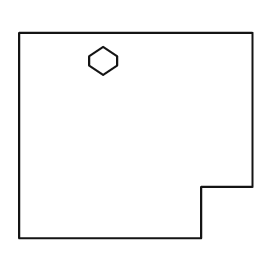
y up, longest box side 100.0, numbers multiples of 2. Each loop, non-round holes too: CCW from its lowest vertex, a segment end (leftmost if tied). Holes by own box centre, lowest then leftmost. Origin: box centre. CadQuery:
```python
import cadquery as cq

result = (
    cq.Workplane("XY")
    .moveTo(-50.0, -44.0)
    .lineTo(28.0, -44.0)
    .lineTo(28.0, -22.0)
    .lineTo(50.0, -22.0)
    .lineTo(50.0, 44.0)
    .lineTo(-50.0, 44.0)
    .close()
    .moveTo(-14.0, 26.0)
    .lineTo(-8.0, 30.0)
    .lineTo(-8.0, 34.0)
    .lineTo(-14.0, 38.0)
    .lineTo(-20.0, 34.0)
    .lineTo(-20.0, 30.0)
    .close()
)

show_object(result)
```